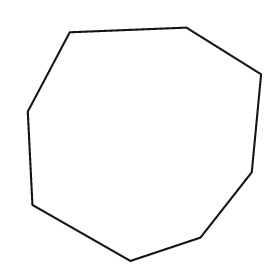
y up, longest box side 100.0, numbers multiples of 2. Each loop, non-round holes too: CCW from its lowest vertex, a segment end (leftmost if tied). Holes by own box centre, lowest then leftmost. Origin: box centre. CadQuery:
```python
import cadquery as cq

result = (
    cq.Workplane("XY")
    .moveTo(-6.0, -50.0)
    .lineTo(24.0, -40.0)
    .lineTo(46.0, -12.0)
    .lineTo(50.0, 30.0)
    .lineTo(18.0, 50.0)
    .lineTo(-32.0, 48.0)
    .lineTo(-50.0, 14.0)
    .lineTo(-48.0, -26.0)
    .close()
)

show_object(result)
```